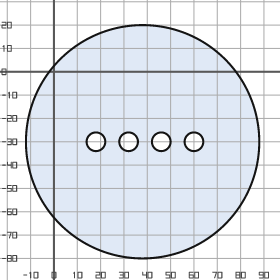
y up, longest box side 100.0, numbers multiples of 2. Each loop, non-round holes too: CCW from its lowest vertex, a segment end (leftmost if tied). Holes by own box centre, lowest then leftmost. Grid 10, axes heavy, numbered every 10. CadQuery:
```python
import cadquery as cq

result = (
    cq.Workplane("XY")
    .moveTo(38.0, -30.0)
    .circle(50.0)
    .moveTo(18.0, -30.0)
    .circle(4.0)
    .moveTo(32.0, -30.0)
    .circle(4.0)
    .moveTo(46.0, -30.0)
    .circle(4.0)
    .moveTo(60.0, -30.0)
    .circle(4.0)
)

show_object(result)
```